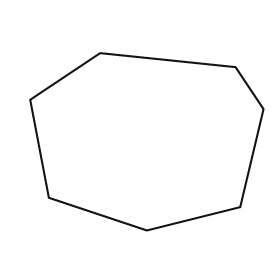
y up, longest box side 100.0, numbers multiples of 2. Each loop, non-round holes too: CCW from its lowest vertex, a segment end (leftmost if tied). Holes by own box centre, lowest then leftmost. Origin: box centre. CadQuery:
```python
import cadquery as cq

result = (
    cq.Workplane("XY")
    .moveTo(0.0, -38.0)
    .lineTo(40.0, -28.0)
    .lineTo(50.0, 14.0)
    .lineTo(38.0, 32.0)
    .lineTo(-20.0, 38.0)
    .lineTo(-50.0, 18.0)
    .lineTo(-42.0, -24.0)
    .close()
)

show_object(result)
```